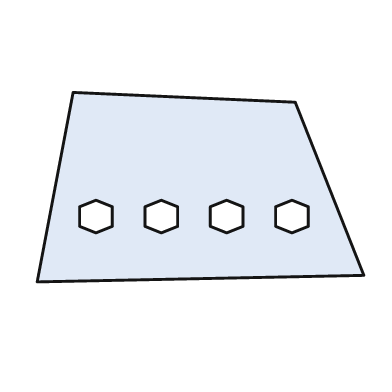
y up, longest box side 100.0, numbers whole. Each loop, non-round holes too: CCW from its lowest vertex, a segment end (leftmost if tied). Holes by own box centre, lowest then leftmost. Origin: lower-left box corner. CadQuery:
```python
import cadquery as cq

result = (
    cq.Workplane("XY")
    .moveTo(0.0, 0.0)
    .lineTo(100.0, 2.0)
    .lineTo(79.0, 55.0)
    .lineTo(11.0, 58.0)
    .close()
    .moveTo(18.0, 15.0)
    .lineTo(23.0, 17.0)
    .lineTo(23.0, 23.0)
    .lineTo(18.0, 25.0)
    .lineTo(13.0, 23.0)
    .lineTo(13.0, 17.0)
    .close()
    .moveTo(38.0, 15.0)
    .lineTo(43.0, 17.0)
    .lineTo(43.0, 23.0)
    .lineTo(38.0, 25.0)
    .lineTo(33.0, 23.0)
    .lineTo(33.0, 17.0)
    .close()
    .moveTo(58.0, 15.0)
    .lineTo(63.0, 17.0)
    .lineTo(63.0, 23.0)
    .lineTo(58.0, 25.0)
    .lineTo(53.0, 23.0)
    .lineTo(53.0, 17.0)
    .close()
    .moveTo(78.0, 15.0)
    .lineTo(83.0, 17.0)
    .lineTo(83.0, 23.0)
    .lineTo(78.0, 25.0)
    .lineTo(73.0, 23.0)
    .lineTo(73.0, 17.0)
    .close()
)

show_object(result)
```